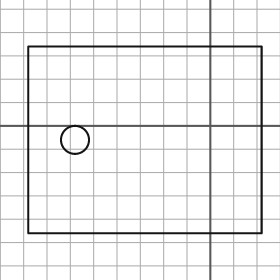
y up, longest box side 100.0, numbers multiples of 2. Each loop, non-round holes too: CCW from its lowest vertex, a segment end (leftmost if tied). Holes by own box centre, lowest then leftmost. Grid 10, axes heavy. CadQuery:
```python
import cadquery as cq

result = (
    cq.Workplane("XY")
    .moveTo(-78.0, -46.0)
    .lineTo(22.0, -46.0)
    .lineTo(22.0, 34.0)
    .lineTo(-78.0, 34.0)
    .close()
    .moveTo(-58.0, -6.0)
    .circle(6.0)
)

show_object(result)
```